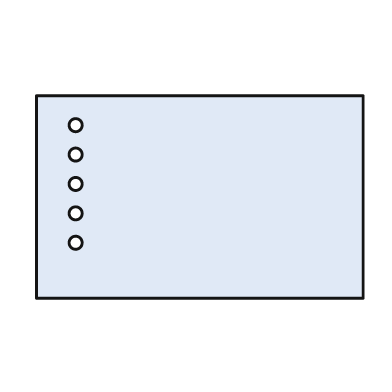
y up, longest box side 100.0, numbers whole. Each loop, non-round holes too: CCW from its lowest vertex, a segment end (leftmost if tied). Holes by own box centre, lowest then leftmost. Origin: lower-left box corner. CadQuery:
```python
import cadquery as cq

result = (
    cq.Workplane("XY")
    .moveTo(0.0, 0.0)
    .lineTo(100.0, 0.0)
    .lineTo(100.0, 62.0)
    .lineTo(0.0, 62.0)
    .close()
    .moveTo(12.0, 17.0)
    .circle(2.0)
    .moveTo(12.0, 26.0)
    .circle(2.0)
    .moveTo(12.0, 35.0)
    .circle(2.0)
    .moveTo(12.0, 44.0)
    .circle(2.0)
    .moveTo(12.0, 53.0)
    .circle(2.0)
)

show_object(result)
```